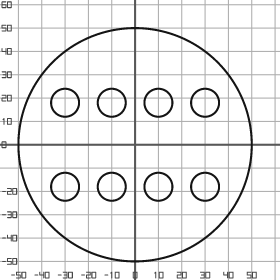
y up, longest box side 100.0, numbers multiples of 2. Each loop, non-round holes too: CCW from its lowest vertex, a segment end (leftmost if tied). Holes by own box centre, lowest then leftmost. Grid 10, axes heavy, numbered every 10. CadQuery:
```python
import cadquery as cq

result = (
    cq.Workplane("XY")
    .moveTo(0.0, 0.0)
    .circle(50.0)
    .moveTo(-30.0, -18.0)
    .circle(6.0)
    .moveTo(-10.0, -18.0)
    .circle(6.0)
    .moveTo(10.0, -18.0)
    .circle(6.0)
    .moveTo(30.0, -18.0)
    .circle(6.0)
    .moveTo(-30.0, 18.0)
    .circle(6.0)
    .moveTo(-10.0, 18.0)
    .circle(6.0)
    .moveTo(10.0, 18.0)
    .circle(6.0)
    .moveTo(30.0, 18.0)
    .circle(6.0)
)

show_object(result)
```